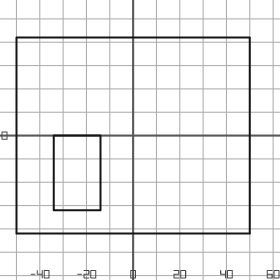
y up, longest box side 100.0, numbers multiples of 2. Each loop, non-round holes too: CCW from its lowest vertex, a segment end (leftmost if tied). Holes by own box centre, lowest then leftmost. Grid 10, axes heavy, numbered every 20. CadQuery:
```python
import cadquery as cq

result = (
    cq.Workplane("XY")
    .moveTo(-50.0, -42.0)
    .lineTo(50.0, -42.0)
    .lineTo(50.0, 42.0)
    .lineTo(-50.0, 42.0)
    .close()
    .moveTo(-34.0, -32.0)
    .lineTo(-14.0, -32.0)
    .lineTo(-14.0, 0.0)
    .lineTo(-34.0, 0.0)
    .close()
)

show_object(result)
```